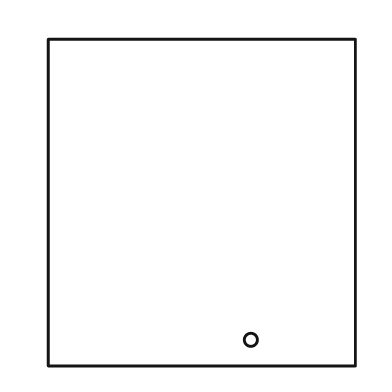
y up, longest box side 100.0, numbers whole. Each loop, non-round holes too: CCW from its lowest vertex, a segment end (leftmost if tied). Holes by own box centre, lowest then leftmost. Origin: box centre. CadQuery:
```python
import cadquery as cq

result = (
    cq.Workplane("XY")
    .moveTo(-47.0, -50.0)
    .lineTo(47.0, -50.0)
    .lineTo(47.0, 50.0)
    .lineTo(-47.0, 50.0)
    .close()
    .moveTo(15.0, -42.0)
    .circle(2.0)
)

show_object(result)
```